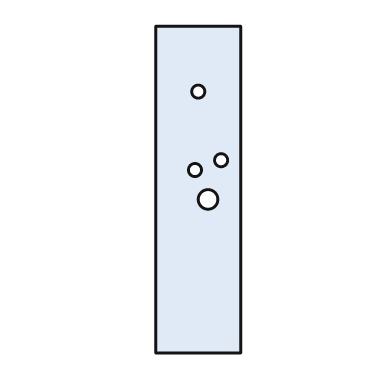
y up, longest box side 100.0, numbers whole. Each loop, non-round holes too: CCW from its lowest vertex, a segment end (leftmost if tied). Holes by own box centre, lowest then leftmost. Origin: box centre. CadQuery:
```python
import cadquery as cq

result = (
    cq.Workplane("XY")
    .moveTo(-13.0, -50.0)
    .lineTo(13.0, -50.0)
    .lineTo(13.0, 50.0)
    .lineTo(-13.0, 50.0)
    .close()
    .moveTo(3.0, -3.0)
    .circle(3.0)
    .moveTo(-1.0, 6.0)
    .circle(2.0)
    .moveTo(7.0, 9.0)
    .circle(2.0)
    .moveTo(0.0, 30.0)
    .circle(2.0)
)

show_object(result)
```